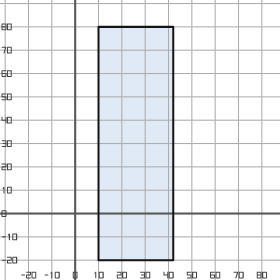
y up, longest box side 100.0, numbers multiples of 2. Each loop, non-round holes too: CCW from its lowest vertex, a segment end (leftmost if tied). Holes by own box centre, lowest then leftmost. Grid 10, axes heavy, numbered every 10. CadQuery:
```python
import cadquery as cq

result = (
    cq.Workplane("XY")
    .moveTo(10.0, -20.0)
    .lineTo(42.0, -20.0)
    .lineTo(42.0, 80.0)
    .lineTo(10.0, 80.0)
    .close()
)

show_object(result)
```